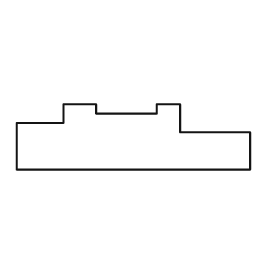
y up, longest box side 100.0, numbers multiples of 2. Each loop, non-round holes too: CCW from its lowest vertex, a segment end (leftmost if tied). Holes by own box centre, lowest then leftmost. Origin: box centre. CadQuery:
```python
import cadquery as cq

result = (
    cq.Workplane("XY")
    .moveTo(-50.0, -14.0)
    .lineTo(50.0, -14.0)
    .lineTo(50.0, 2.0)
    .lineTo(20.0, 2.0)
    .lineTo(20.0, 14.0)
    .lineTo(10.0, 14.0)
    .lineTo(10.0, 10.0)
    .lineTo(-16.0, 10.0)
    .lineTo(-16.0, 14.0)
    .lineTo(-30.0, 14.0)
    .lineTo(-30.0, 6.0)
    .lineTo(-50.0, 6.0)
    .close()
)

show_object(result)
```